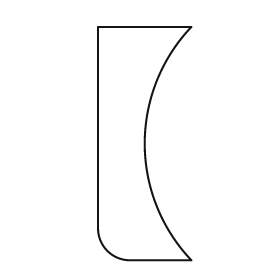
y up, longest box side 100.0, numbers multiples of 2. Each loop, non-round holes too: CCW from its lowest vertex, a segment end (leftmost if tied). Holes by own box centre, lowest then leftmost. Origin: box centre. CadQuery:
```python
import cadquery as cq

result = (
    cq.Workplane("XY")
    .moveTo(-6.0, -50.0)
    .lineTo(20.0, -50.0)
    .threePointArc((0.0, 0.0), (20.0, 50.0))
    .lineTo(-20.0, 50.0)
    .lineTo(-20.0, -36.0)
    .threePointArc((-16.0, -46.0), (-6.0, -50.0))
    .close()
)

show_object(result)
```